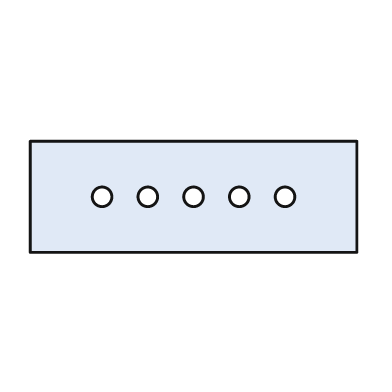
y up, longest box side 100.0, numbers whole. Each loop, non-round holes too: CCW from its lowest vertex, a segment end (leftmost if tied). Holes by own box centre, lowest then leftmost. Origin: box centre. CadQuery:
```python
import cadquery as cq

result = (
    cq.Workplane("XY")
    .moveTo(-50.0, -17.0)
    .lineTo(50.0, -17.0)
    .lineTo(50.0, 17.0)
    .lineTo(-50.0, 17.0)
    .close()
    .moveTo(-28.0, 0.0)
    .circle(3.0)
    .moveTo(-14.0, 0.0)
    .circle(3.0)
    .moveTo(0.0, 0.0)
    .circle(3.0)
    .moveTo(14.0, 0.0)
    .circle(3.0)
    .moveTo(28.0, 0.0)
    .circle(3.0)
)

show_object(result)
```